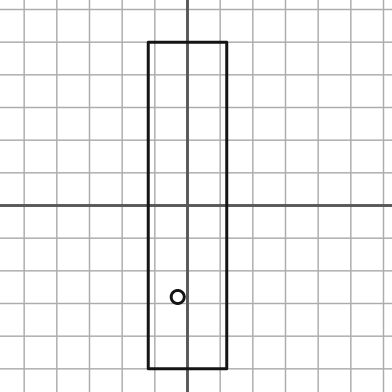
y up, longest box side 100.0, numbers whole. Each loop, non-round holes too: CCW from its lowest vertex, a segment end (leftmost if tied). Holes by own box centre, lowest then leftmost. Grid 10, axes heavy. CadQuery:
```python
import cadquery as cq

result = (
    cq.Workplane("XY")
    .moveTo(-12.0, -50.0)
    .lineTo(12.0, -50.0)
    .lineTo(12.0, 50.0)
    .lineTo(-12.0, 50.0)
    .close()
    .moveTo(-3.0, -28.0)
    .circle(2.0)
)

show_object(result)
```